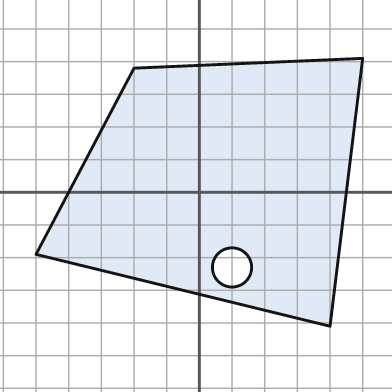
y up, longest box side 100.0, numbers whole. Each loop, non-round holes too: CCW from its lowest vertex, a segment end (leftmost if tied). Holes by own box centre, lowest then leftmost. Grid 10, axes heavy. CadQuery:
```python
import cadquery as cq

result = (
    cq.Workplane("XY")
    .moveTo(40.0, -41.0)
    .lineTo(50.0, 41.0)
    .lineTo(-20.0, 38.0)
    .lineTo(-50.0, -19.0)
    .close()
    .moveTo(10.0, -23.0)
    .circle(6.0)
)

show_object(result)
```